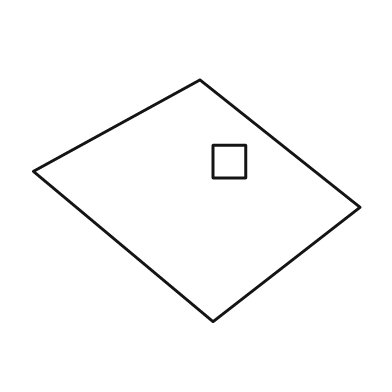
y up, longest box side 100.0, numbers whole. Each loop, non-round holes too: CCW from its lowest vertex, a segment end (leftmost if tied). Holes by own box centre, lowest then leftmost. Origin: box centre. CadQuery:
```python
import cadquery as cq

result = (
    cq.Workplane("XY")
    .moveTo(5.0, -37.0)
    .lineTo(50.0, -2.0)
    .lineTo(1.0, 37.0)
    .lineTo(-50.0, 9.0)
    .close()
    .moveTo(5.0, 7.0)
    .lineTo(15.0, 7.0)
    .lineTo(15.0, 17.0)
    .lineTo(5.0, 17.0)
    .close()
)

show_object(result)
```